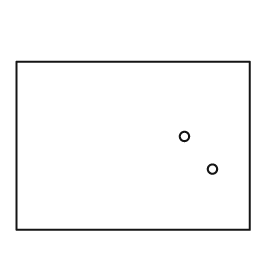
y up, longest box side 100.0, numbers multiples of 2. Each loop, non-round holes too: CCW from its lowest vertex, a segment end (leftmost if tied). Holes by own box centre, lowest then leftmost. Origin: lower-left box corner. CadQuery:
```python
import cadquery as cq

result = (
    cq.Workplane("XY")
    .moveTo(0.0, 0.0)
    .lineTo(100.0, 0.0)
    .lineTo(100.0, 72.0)
    .lineTo(0.0, 72.0)
    .close()
    .moveTo(84.0, 26.0)
    .circle(2.0)
    .moveTo(72.0, 40.0)
    .circle(2.0)
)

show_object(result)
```